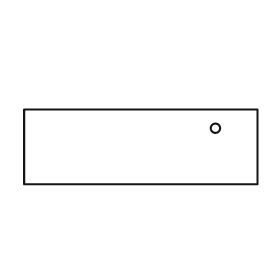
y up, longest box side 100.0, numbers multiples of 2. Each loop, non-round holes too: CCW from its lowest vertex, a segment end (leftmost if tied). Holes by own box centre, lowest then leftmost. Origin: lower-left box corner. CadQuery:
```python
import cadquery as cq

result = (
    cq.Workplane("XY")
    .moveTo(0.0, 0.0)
    .lineTo(100.0, 0.0)
    .lineTo(100.0, 32.0)
    .lineTo(0.0, 32.0)
    .close()
    .moveTo(82.0, 24.0)
    .circle(2.0)
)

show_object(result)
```